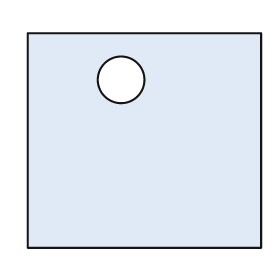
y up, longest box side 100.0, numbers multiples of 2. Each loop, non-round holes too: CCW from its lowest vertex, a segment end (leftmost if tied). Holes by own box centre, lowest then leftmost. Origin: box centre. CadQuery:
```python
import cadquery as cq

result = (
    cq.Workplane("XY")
    .moveTo(-50.0, -46.0)
    .lineTo(50.0, -46.0)
    .lineTo(50.0, 46.0)
    .lineTo(-50.0, 46.0)
    .close()
    .moveTo(-10.0, 26.0)
    .circle(10.0)
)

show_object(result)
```